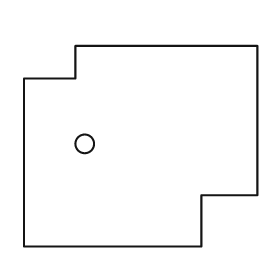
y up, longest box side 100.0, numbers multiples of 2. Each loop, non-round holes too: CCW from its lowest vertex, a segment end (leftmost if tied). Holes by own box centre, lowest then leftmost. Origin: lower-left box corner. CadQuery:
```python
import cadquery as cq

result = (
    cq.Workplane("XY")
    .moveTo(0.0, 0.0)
    .lineTo(76.0, 0.0)
    .lineTo(76.0, 22.0)
    .lineTo(100.0, 22.0)
    .lineTo(100.0, 86.0)
    .lineTo(22.0, 86.0)
    .lineTo(22.0, 72.0)
    .lineTo(0.0, 72.0)
    .close()
    .moveTo(26.0, 44.0)
    .circle(4.0)
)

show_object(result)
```